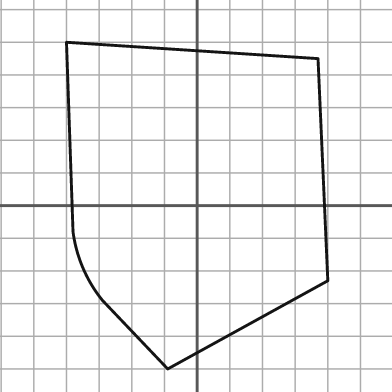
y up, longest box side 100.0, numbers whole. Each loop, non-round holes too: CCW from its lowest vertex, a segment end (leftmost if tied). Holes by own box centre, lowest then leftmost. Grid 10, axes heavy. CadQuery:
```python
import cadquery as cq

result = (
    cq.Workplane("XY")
    .moveTo(-9.0, -50.0)
    .lineTo(40.0, -23.0)
    .lineTo(37.0, 45.0)
    .lineTo(-40.0, 50.0)
    .lineTo(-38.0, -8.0)
    .threePointArc((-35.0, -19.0), (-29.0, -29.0))
    .close()
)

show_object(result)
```